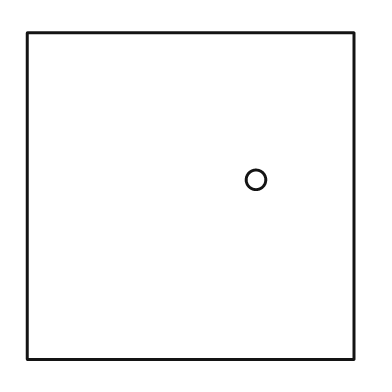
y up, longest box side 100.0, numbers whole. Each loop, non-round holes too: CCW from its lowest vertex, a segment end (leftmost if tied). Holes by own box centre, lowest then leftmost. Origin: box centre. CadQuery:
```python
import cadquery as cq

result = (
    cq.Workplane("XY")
    .moveTo(-50.0, -50.0)
    .lineTo(50.0, -50.0)
    .lineTo(50.0, 50.0)
    .lineTo(-50.0, 50.0)
    .close()
    .moveTo(20.0, 5.0)
    .circle(3.0)
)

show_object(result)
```